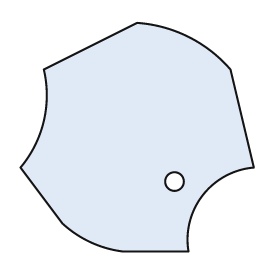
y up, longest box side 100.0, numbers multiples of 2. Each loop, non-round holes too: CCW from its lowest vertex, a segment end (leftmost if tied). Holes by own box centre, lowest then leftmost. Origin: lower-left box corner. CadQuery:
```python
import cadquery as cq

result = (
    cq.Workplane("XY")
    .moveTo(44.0, 0.0)
    .lineTo(72.0, 0.0)
    .threePointArc((78.0, 24.0), (100.0, 36.0))
    .lineTo(90.0, 78.0)
    .threePointArc((72.0, 92.0), (50.0, 98.0))
    .lineTo(10.0, 78.0)
    .threePointArc((10.0, 56.0), (0.0, 36.0))
    .lineTo(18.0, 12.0)
    .threePointArc((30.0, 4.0), (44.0, 0.0))
    .close()
    .moveTo(66.0, 30.0)
    .circle(4.0)
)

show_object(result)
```